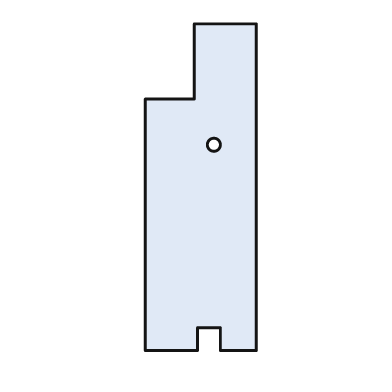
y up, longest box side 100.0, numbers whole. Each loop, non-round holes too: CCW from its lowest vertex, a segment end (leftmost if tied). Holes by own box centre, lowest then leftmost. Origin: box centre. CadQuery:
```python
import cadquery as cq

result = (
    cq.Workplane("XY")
    .moveTo(-17.0, -50.0)
    .lineTo(-1.0, -50.0)
    .lineTo(-1.0, -43.0)
    .lineTo(6.0, -43.0)
    .lineTo(6.0, -50.0)
    .lineTo(17.0, -50.0)
    .lineTo(17.0, 50.0)
    .lineTo(-2.0, 50.0)
    .lineTo(-2.0, 27.0)
    .lineTo(-17.0, 27.0)
    .close()
    .moveTo(4.0, 13.0)
    .circle(2.0)
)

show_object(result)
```